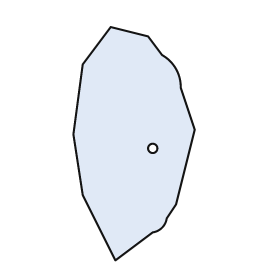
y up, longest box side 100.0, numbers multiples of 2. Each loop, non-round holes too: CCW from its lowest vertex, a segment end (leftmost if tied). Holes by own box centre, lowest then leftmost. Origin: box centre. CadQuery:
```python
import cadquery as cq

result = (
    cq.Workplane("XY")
    .moveTo(-8.0, -50.0)
    .lineTo(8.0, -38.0)
    .threePointArc((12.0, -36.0), (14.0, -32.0))
    .lineTo(18.0, -26.0)
    .lineTo(26.0, 6.0)
    .lineTo(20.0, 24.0)
    .threePointArc((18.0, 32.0), (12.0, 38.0))
    .lineTo(6.0, 46.0)
    .lineTo(-10.0, 50.0)
    .lineTo(-22.0, 34.0)
    .lineTo(-26.0, 4.0)
    .lineTo(-22.0, -22.0)
    .close()
    .moveTo(8.0, -2.0)
    .circle(2.0)
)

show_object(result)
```